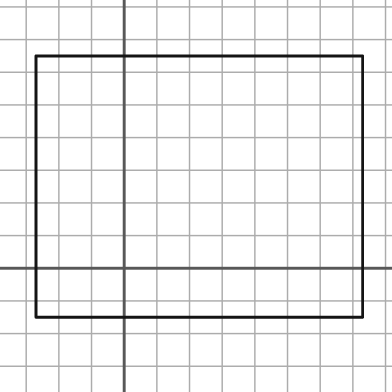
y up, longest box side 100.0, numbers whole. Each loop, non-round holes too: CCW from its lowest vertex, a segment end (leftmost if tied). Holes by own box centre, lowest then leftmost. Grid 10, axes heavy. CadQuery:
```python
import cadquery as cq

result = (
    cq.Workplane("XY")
    .moveTo(-27.0, -15.0)
    .lineTo(73.0, -15.0)
    .lineTo(73.0, 65.0)
    .lineTo(-27.0, 65.0)
    .close()
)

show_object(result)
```